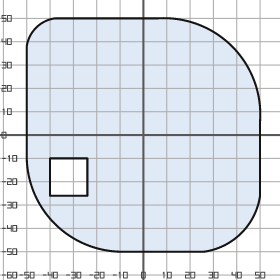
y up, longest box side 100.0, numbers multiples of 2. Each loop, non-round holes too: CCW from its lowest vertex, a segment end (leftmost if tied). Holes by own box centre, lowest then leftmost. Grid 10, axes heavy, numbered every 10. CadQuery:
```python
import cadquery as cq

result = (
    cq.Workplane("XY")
    .moveTo(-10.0, -50.0)
    .lineTo(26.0, -50.0)
    .threePointArc((42.0, -42.0), (50.0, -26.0))
    .lineTo(50.0, 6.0)
    .threePointArc((38.0, 38.0), (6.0, 50.0))
    .lineTo(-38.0, 50.0)
    .threePointArc((-46.0, 46.0), (-50.0, 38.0))
    .lineTo(-50.0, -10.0)
    .threePointArc((-38.0, -38.0), (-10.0, -50.0))
    .close()
    .moveTo(-40.0, -26.0)
    .lineTo(-24.0, -26.0)
    .lineTo(-24.0, -10.0)
    .lineTo(-40.0, -10.0)
    .close()
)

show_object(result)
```